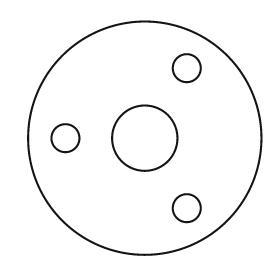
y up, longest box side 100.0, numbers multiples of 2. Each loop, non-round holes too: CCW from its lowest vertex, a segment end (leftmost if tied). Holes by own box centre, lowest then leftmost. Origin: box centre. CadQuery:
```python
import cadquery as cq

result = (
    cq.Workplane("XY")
    .moveTo(0.0, 0.0)
    .circle(50.0)
    .moveTo(18.0, -30.0)
    .circle(6.0)
    .moveTo(-34.0, 0.0)
    .circle(6.0)
    .moveTo(0.0, 0.0)
    .circle(14.0)
    .moveTo(18.0, 30.0)
    .circle(6.0)
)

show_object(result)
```